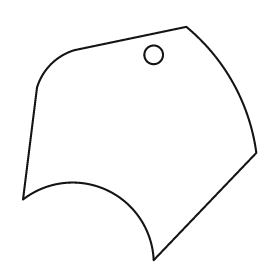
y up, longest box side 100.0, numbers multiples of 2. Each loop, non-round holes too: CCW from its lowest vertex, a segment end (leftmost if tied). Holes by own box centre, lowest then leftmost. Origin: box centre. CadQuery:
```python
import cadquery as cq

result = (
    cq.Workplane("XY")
    .moveTo(6.0, -50.0)
    .lineTo(50.0, -4.0)
    .threePointArc((40.0, 26.0), (20.0, 50.0))
    .lineTo(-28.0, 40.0)
    .threePointArc((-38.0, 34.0), (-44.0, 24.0))
    .lineTo(-50.0, -24.0)
    .threePointArc((-14.0, -20.0), (6.0, -50.0))
    .close()
    .moveTo(6.0, 38.0)
    .circle(4.0)
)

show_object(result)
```